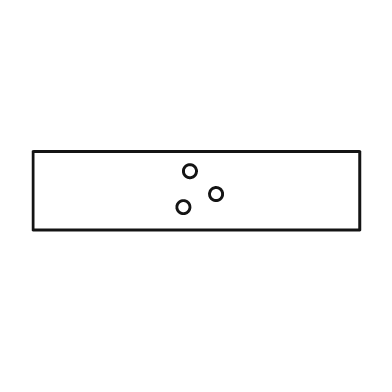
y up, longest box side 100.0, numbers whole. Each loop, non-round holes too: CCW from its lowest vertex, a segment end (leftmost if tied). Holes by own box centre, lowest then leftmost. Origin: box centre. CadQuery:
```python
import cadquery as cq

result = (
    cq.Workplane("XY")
    .moveTo(-50.0, -12.0)
    .lineTo(50.0, -12.0)
    .lineTo(50.0, 12.0)
    .lineTo(-50.0, 12.0)
    .close()
    .moveTo(-4.0, -5.0)
    .circle(2.0)
    .moveTo(6.0, -1.0)
    .circle(2.0)
    .moveTo(-2.0, 6.0)
    .circle(2.0)
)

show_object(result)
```